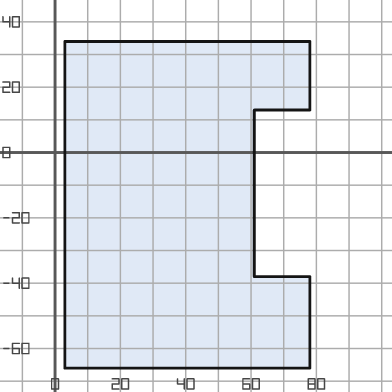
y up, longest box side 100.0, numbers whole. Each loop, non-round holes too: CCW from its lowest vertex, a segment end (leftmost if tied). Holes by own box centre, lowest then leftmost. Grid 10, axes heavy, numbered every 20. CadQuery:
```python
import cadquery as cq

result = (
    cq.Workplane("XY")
    .moveTo(3.0, -66.0)
    .lineTo(78.0, -66.0)
    .lineTo(78.0, -38.0)
    .lineTo(61.0, -38.0)
    .lineTo(61.0, 13.0)
    .lineTo(78.0, 13.0)
    .lineTo(78.0, 34.0)
    .lineTo(3.0, 34.0)
    .close()
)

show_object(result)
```